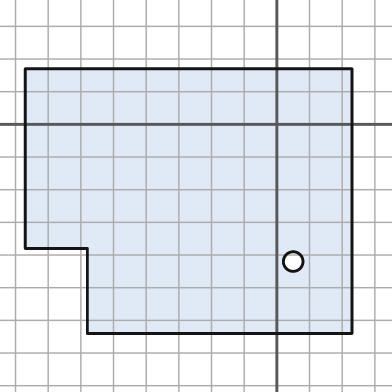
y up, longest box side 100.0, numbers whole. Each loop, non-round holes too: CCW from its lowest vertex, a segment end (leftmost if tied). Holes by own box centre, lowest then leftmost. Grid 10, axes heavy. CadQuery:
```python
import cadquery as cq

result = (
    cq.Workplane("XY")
    .moveTo(-58.0, -64.0)
    .lineTo(23.0, -64.0)
    .lineTo(23.0, 17.0)
    .lineTo(-77.0, 17.0)
    .lineTo(-77.0, -38.0)
    .lineTo(-58.0, -38.0)
    .close()
    .moveTo(5.0, -42.0)
    .circle(3.0)
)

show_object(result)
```